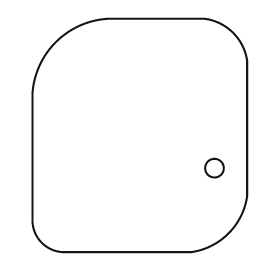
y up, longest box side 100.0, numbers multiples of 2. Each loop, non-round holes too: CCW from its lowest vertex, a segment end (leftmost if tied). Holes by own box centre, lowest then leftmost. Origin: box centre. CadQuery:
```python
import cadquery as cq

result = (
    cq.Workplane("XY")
    .moveTo(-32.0, -50.0)
    .lineTo(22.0, -50.0)
    .threePointArc((38.0, -42.0), (46.0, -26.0))
    .lineTo(46.0, 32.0)
    .threePointArc((40.0, 44.0), (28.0, 50.0))
    .lineTo(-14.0, 50.0)
    .threePointArc((-36.0, 40.0), (-46.0, 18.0))
    .lineTo(-46.0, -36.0)
    .threePointArc((-42.0, -46.0), (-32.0, -50.0))
    .close()
    .moveTo(32.0, -14.0)
    .circle(4.0)
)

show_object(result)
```